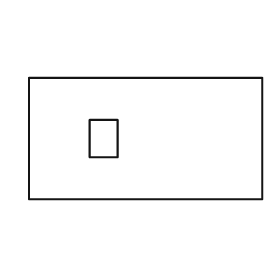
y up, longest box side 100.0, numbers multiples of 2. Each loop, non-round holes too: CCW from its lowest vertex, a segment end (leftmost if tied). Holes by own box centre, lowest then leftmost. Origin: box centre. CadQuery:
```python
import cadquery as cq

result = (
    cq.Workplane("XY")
    .moveTo(-50.0, -26.0)
    .lineTo(50.0, -26.0)
    .lineTo(50.0, 26.0)
    .lineTo(-50.0, 26.0)
    .close()
    .moveTo(-24.0, -8.0)
    .lineTo(-12.0, -8.0)
    .lineTo(-12.0, 8.0)
    .lineTo(-24.0, 8.0)
    .close()
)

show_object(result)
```